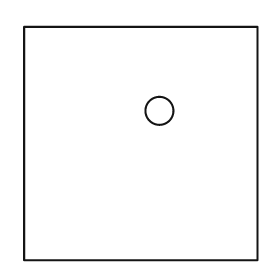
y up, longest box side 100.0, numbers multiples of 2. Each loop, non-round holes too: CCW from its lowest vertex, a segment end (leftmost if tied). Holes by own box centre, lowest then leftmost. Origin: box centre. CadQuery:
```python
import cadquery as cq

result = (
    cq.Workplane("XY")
    .moveTo(-50.0, -50.0)
    .lineTo(50.0, -50.0)
    .lineTo(50.0, 50.0)
    .lineTo(-50.0, 50.0)
    .close()
    .moveTo(8.0, 14.0)
    .circle(6.0)
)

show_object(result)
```